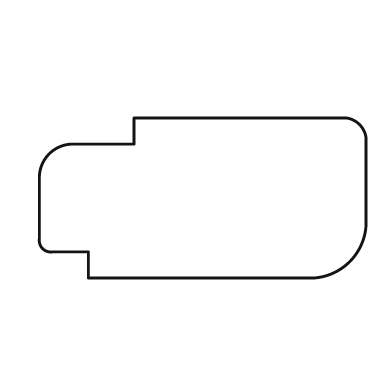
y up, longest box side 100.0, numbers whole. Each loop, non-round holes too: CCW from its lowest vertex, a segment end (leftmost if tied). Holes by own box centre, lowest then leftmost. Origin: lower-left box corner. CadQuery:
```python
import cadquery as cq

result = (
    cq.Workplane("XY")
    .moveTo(15.0, 0.0)
    .lineTo(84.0, 0.0)
    .threePointArc((95.0, 5.0), (100.0, 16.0))
    .lineTo(100.0, 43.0)
    .threePointArc((98.0, 47.0), (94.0, 49.0))
    .lineTo(29.0, 49.0)
    .lineTo(29.0, 41.0)
    .lineTo(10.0, 41.0)
    .threePointArc((3.0, 38.0), (0.0, 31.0))
    .lineTo(0.0, 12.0)
    .threePointArc((1.0, 9.0), (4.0, 8.0))
    .lineTo(15.0, 8.0)
    .close()
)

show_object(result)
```